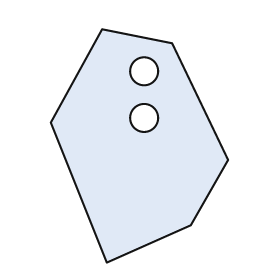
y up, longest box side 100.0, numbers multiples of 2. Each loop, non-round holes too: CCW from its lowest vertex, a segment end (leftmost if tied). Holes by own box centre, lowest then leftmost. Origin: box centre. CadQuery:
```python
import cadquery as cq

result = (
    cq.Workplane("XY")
    .moveTo(-14.0, -50.0)
    .lineTo(22.0, -34.0)
    .lineTo(38.0, -6.0)
    .lineTo(14.0, 44.0)
    .lineTo(-16.0, 50.0)
    .lineTo(-38.0, 10.0)
    .close()
    .moveTo(2.0, 12.0)
    .circle(6.0)
    .moveTo(2.0, 32.0)
    .circle(6.0)
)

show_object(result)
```